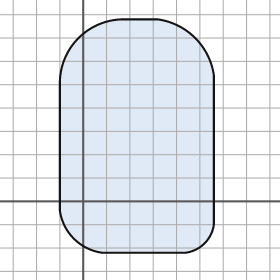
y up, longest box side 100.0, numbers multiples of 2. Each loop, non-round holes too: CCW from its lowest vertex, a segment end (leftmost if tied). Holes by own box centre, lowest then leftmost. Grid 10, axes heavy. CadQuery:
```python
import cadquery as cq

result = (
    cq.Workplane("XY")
    .moveTo(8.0, -22.0)
    .lineTo(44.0, -22.0)
    .threePointArc((52.0, -18.0), (56.0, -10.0))
    .lineTo(56.0, 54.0)
    .threePointArc((48.0, 70.0), (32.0, 78.0))
    .lineTo(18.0, 78.0)
    .threePointArc((-2.0, 70.0), (-10.0, 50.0))
    .lineTo(-10.0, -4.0)
    .threePointArc((-4.0, -16.0), (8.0, -22.0))
    .close()
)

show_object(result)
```